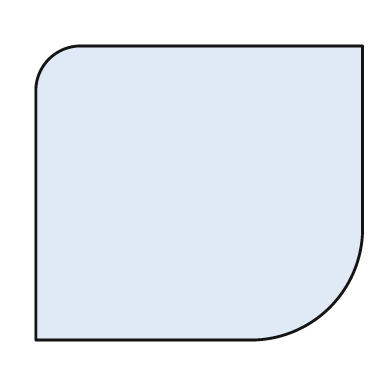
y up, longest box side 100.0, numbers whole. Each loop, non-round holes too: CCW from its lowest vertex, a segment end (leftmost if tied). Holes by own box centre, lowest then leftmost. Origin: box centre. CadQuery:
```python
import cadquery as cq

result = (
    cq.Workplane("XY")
    .moveTo(-50.0, -45.0)
    .lineTo(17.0, -45.0)
    .threePointArc((40.0, -35.0), (50.0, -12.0))
    .lineTo(50.0, 45.0)
    .lineTo(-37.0, 45.0)
    .threePointArc((-46.0, 41.0), (-50.0, 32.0))
    .close()
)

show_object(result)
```